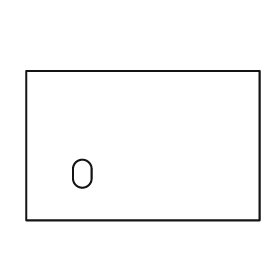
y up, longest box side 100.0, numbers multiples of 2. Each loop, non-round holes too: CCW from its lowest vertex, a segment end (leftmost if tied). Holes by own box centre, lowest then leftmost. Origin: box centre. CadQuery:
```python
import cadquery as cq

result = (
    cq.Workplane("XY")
    .moveTo(-50.0, -32.0)
    .lineTo(50.0, -32.0)
    .lineTo(50.0, 32.0)
    .lineTo(-50.0, 32.0)
    .close()
    .moveTo(-30.0, -14.0)
    .threePointArc((-26.0, -18.0), (-22.0, -14.0))
    .lineTo(-22.0, -10.0)
    .threePointArc((-26.0, -6.0), (-30.0, -10.0))
    .close()
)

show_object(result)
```